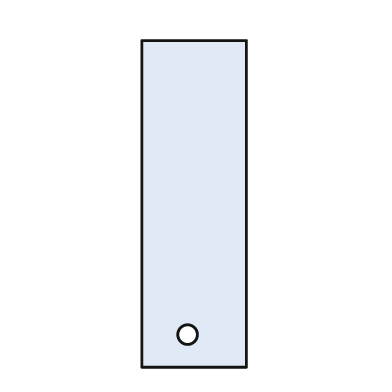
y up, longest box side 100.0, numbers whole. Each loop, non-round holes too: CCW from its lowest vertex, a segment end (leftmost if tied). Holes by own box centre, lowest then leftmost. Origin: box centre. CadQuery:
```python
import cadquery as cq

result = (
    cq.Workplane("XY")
    .moveTo(-16.0, -50.0)
    .lineTo(16.0, -50.0)
    .lineTo(16.0, 50.0)
    .lineTo(-16.0, 50.0)
    .close()
    .moveTo(-2.0, -40.0)
    .circle(3.0)
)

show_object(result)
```